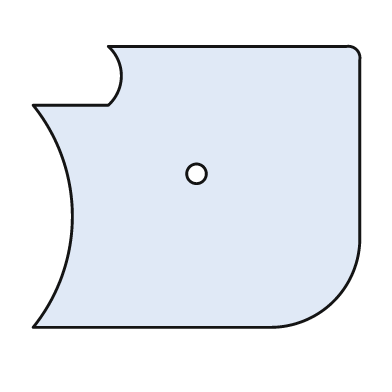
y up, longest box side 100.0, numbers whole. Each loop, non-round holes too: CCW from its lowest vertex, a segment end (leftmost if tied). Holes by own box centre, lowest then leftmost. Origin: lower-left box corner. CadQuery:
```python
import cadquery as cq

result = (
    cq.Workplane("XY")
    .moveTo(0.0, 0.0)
    .lineTo(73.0, 0.0)
    .threePointArc((92.0, 8.0), (100.0, 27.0))
    .lineTo(100.0, 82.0)
    .threePointArc((99.0, 85.0), (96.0, 86.0))
    .lineTo(23.0, 86.0)
    .threePointArc((27.0, 77.0), (23.0, 68.0))
    .lineTo(0.0, 68.0)
    .threePointArc((12.0, 34.0), (0.0, 0.0))
    .close()
    .moveTo(50.0, 47.0)
    .circle(3.0)
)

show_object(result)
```